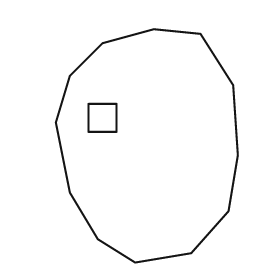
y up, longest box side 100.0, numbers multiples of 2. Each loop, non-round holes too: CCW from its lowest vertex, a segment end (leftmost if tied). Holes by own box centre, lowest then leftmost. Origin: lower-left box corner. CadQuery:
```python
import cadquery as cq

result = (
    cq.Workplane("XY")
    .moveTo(34.0, 0.0)
    .lineTo(58.0, 4.0)
    .lineTo(74.0, 22.0)
    .lineTo(78.0, 46.0)
    .lineTo(76.0, 76.0)
    .lineTo(62.0, 98.0)
    .lineTo(42.0, 100.0)
    .lineTo(20.0, 94.0)
    .lineTo(6.0, 80.0)
    .lineTo(0.0, 60.0)
    .lineTo(6.0, 30.0)
    .lineTo(18.0, 10.0)
    .close()
    .moveTo(14.0, 56.0)
    .lineTo(26.0, 56.0)
    .lineTo(26.0, 68.0)
    .lineTo(14.0, 68.0)
    .close()
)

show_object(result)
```